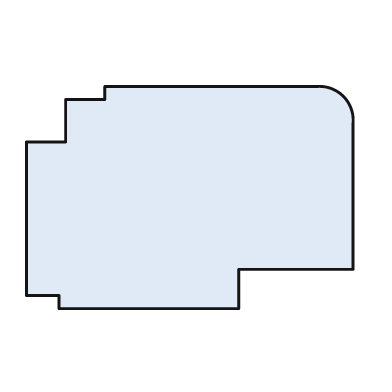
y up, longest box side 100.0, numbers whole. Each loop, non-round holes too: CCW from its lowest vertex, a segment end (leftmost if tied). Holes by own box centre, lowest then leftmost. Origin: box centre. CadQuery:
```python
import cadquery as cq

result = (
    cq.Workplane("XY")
    .moveTo(-40.0, -34.0)
    .lineTo(15.0, -34.0)
    .lineTo(15.0, -22.0)
    .lineTo(50.0, -22.0)
    .lineTo(50.0, 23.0)
    .threePointArc((47.0, 31.0), (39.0, 34.0))
    .lineTo(-26.0, 34.0)
    .lineTo(-26.0, 30.0)
    .lineTo(-38.0, 30.0)
    .lineTo(-38.0, 17.0)
    .lineTo(-50.0, 17.0)
    .lineTo(-50.0, -30.0)
    .lineTo(-40.0, -30.0)
    .close()
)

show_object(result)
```